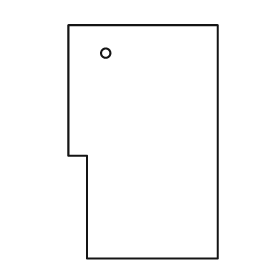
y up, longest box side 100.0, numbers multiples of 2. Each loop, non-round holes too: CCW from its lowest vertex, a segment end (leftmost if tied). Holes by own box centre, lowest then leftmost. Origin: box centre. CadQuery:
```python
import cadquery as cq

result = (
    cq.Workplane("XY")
    .moveTo(-24.0, -50.0)
    .lineTo(32.0, -50.0)
    .lineTo(32.0, 50.0)
    .lineTo(-32.0, 50.0)
    .lineTo(-32.0, -6.0)
    .lineTo(-24.0, -6.0)
    .close()
    .moveTo(-16.0, 38.0)
    .circle(2.0)
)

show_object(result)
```